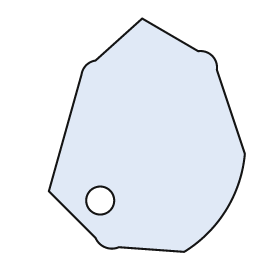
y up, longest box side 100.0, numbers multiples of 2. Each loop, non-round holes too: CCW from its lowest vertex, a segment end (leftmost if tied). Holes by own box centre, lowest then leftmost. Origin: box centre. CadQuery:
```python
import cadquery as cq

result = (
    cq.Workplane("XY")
    .moveTo(16.0, -50.0)
    .threePointArc((34.0, -32.0), (42.0, -8.0))
    .lineTo(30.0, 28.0)
    .threePointArc((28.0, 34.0), (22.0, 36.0))
    .lineTo(-2.0, 50.0)
    .lineTo(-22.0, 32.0)
    .threePointArc((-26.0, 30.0), (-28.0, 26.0))
    .lineTo(-42.0, -24.0)
    .lineTo(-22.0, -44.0)
    .threePointArc((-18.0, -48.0), (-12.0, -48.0))
    .close()
    .moveTo(-20.0, -28.0)
    .circle(6.0)
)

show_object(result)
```